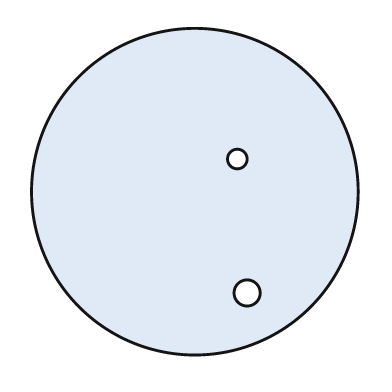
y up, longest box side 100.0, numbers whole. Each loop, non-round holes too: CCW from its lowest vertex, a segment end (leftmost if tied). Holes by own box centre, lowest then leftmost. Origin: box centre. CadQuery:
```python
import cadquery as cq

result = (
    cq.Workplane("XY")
    .moveTo(0.0, 0.0)
    .circle(50.0)
    .moveTo(16.0, -31.0)
    .circle(4.0)
    .moveTo(13.0, 10.0)
    .circle(3.0)
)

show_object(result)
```